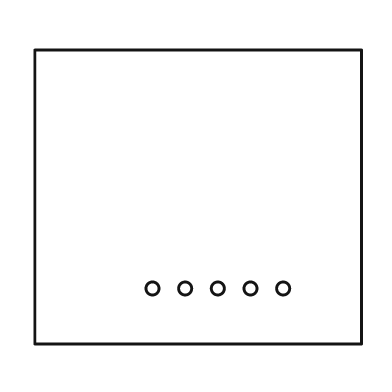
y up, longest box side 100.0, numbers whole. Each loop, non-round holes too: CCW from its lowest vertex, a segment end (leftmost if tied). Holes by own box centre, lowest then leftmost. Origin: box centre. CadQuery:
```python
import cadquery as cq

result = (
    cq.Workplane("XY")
    .moveTo(-50.0, -45.0)
    .lineTo(50.0, -45.0)
    .lineTo(50.0, 45.0)
    .lineTo(-50.0, 45.0)
    .close()
    .moveTo(-14.0, -28.0)
    .circle(2.0)
    .moveTo(-4.0, -28.0)
    .circle(2.0)
    .moveTo(6.0, -28.0)
    .circle(2.0)
    .moveTo(16.0, -28.0)
    .circle(2.0)
    .moveTo(26.0, -28.0)
    .circle(2.0)
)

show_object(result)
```